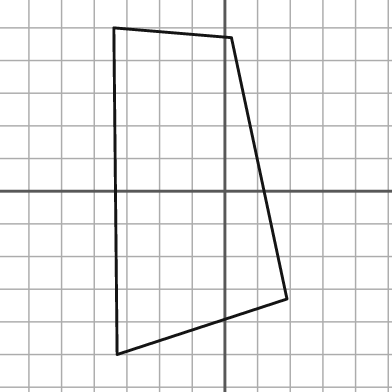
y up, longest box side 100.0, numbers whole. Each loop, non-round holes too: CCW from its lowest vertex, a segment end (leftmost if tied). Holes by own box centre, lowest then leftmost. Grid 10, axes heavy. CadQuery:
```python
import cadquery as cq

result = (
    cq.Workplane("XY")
    .moveTo(-33.0, -50.0)
    .lineTo(19.0, -33.0)
    .lineTo(2.0, 47.0)
    .lineTo(-34.0, 50.0)
    .close()
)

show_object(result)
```